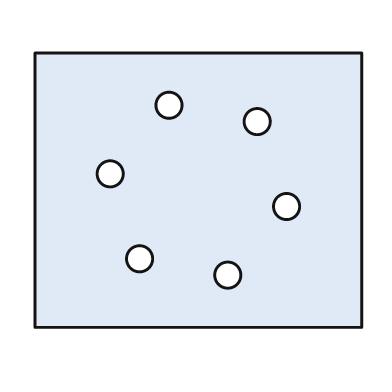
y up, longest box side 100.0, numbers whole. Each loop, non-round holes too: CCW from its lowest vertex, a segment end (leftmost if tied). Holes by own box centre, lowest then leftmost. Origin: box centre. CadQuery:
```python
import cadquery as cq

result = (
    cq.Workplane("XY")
    .moveTo(-50.0, -42.0)
    .lineTo(50.0, -42.0)
    .lineTo(50.0, 42.0)
    .lineTo(-50.0, 42.0)
    .close()
    .moveTo(9.0, -26.0)
    .circle(4.0)
    .moveTo(-18.0, -21.0)
    .circle(4.0)
    .moveTo(27.0, -5.0)
    .circle(4.0)
    .moveTo(-27.0, 5.0)
    .circle(4.0)
    .moveTo(18.0, 21.0)
    .circle(4.0)
    .moveTo(-9.0, 26.0)
    .circle(4.0)
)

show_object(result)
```